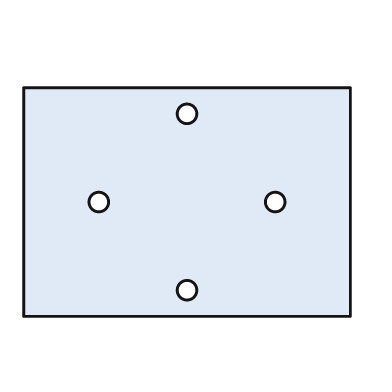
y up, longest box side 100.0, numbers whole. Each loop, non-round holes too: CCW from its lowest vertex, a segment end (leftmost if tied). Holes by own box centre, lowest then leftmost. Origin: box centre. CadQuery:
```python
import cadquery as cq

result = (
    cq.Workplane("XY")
    .moveTo(-50.0, -35.0)
    .lineTo(50.0, -35.0)
    .lineTo(50.0, 35.0)
    .lineTo(-50.0, 35.0)
    .close()
    .moveTo(0.0, -27.0)
    .circle(3.0)
    .moveTo(-27.0, 0.0)
    .circle(3.0)
    .moveTo(27.0, 0.0)
    .circle(3.0)
    .moveTo(0.0, 27.0)
    .circle(3.0)
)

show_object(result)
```